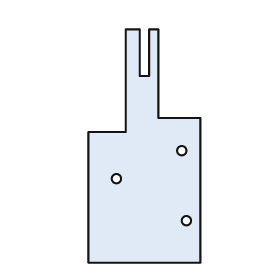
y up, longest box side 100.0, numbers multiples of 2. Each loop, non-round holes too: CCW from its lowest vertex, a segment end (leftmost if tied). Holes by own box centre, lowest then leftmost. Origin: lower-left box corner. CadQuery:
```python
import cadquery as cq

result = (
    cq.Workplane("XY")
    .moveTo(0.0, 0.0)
    .lineTo(48.0, 0.0)
    .lineTo(48.0, 62.0)
    .lineTo(30.0, 62.0)
    .lineTo(30.0, 100.0)
    .lineTo(26.0, 100.0)
    .lineTo(26.0, 80.0)
    .lineTo(22.0, 80.0)
    .lineTo(22.0, 100.0)
    .lineTo(16.0, 100.0)
    .lineTo(16.0, 56.0)
    .lineTo(0.0, 56.0)
    .close()
    .moveTo(42.0, 18.0)
    .circle(2.0)
    .moveTo(12.0, 36.0)
    .circle(2.0)
    .moveTo(40.0, 48.0)
    .circle(2.0)
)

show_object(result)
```